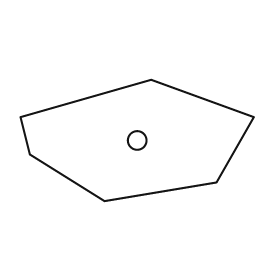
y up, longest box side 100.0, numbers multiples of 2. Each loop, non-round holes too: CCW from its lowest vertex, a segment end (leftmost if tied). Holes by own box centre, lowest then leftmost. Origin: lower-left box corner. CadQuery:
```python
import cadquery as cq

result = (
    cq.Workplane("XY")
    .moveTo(36.0, 0.0)
    .lineTo(84.0, 8.0)
    .lineTo(100.0, 36.0)
    .lineTo(56.0, 52.0)
    .lineTo(0.0, 36.0)
    .lineTo(4.0, 20.0)
    .close()
    .moveTo(50.0, 26.0)
    .circle(4.0)
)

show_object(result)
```